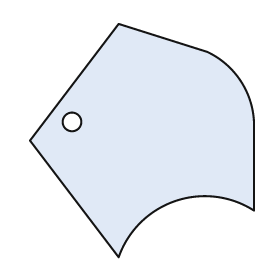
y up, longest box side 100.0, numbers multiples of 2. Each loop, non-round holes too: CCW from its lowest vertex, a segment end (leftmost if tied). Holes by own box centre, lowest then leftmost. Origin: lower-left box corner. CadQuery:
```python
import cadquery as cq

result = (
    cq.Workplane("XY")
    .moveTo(38.0, 0.0)
    .threePointArc((62.0, 24.0), (96.0, 20.0))
    .lineTo(96.0, 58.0)
    .threePointArc((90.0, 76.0), (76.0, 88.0))
    .lineTo(38.0, 100.0)
    .lineTo(0.0, 50.0)
    .close()
    .moveTo(18.0, 58.0)
    .circle(4.0)
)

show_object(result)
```